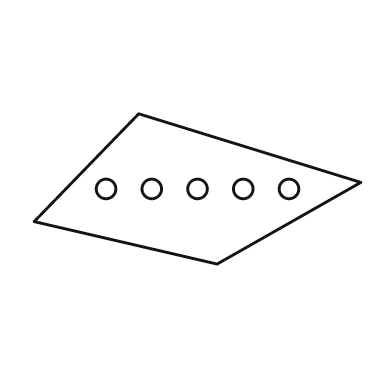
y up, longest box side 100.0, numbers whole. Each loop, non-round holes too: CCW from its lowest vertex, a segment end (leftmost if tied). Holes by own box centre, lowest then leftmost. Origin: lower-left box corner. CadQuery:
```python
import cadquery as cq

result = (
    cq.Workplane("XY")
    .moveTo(56.0, 0.0)
    .lineTo(100.0, 25.0)
    .lineTo(32.0, 46.0)
    .lineTo(0.0, 13.0)
    .close()
    .moveTo(22.0, 23.0)
    .circle(3.0)
    .moveTo(36.0, 23.0)
    .circle(3.0)
    .moveTo(50.0, 23.0)
    .circle(3.0)
    .moveTo(64.0, 23.0)
    .circle(3.0)
    .moveTo(78.0, 23.0)
    .circle(3.0)
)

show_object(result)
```